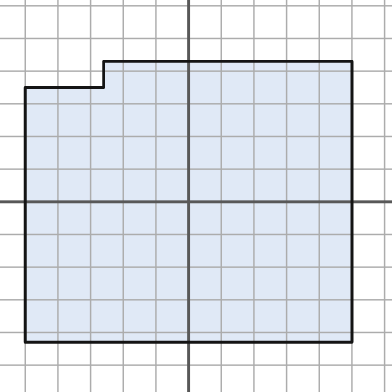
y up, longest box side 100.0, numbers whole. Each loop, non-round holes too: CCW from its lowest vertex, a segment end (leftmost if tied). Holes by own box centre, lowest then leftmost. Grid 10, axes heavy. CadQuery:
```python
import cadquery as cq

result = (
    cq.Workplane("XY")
    .moveTo(-50.0, -43.0)
    .lineTo(50.0, -43.0)
    .lineTo(50.0, 43.0)
    .lineTo(-26.0, 43.0)
    .lineTo(-26.0, 35.0)
    .lineTo(-50.0, 35.0)
    .close()
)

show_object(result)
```